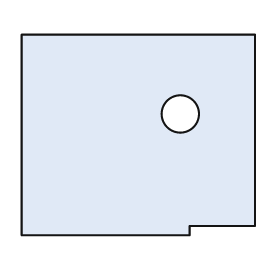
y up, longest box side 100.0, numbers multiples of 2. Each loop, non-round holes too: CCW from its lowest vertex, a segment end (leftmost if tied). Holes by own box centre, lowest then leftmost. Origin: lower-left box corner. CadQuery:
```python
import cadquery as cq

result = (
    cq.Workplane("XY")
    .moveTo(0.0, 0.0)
    .lineTo(72.0, 0.0)
    .lineTo(72.0, 4.0)
    .lineTo(100.0, 4.0)
    .lineTo(100.0, 86.0)
    .lineTo(0.0, 86.0)
    .close()
    .moveTo(68.0, 52.0)
    .circle(8.0)
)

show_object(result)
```